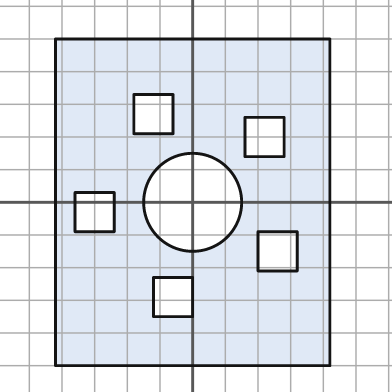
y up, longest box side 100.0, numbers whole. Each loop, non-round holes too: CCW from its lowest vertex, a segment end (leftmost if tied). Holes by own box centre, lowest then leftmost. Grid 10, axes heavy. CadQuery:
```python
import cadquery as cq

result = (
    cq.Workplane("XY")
    .moveTo(-42.0, -50.0)
    .lineTo(42.0, -50.0)
    .lineTo(42.0, 50.0)
    .lineTo(-42.0, 50.0)
    .close()
    .moveTo(-12.0, -35.0)
    .lineTo(0.0, -35.0)
    .lineTo(0.0, -23.0)
    .lineTo(-12.0, -23.0)
    .close()
    .moveTo(20.0, -21.0)
    .lineTo(32.0, -21.0)
    .lineTo(32.0, -9.0)
    .lineTo(20.0, -9.0)
    .close()
    .moveTo(-36.0, -9.0)
    .lineTo(-24.0, -9.0)
    .lineTo(-24.0, 3.0)
    .lineTo(-36.0, 3.0)
    .close()
    .moveTo(0.0, 0.0)
    .circle(15.0)
    .moveTo(16.0, 14.0)
    .lineTo(28.0, 14.0)
    .lineTo(28.0, 26.0)
    .lineTo(16.0, 26.0)
    .close()
    .moveTo(-18.0, 21.0)
    .lineTo(-6.0, 21.0)
    .lineTo(-6.0, 33.0)
    .lineTo(-18.0, 33.0)
    .close()
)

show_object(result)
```